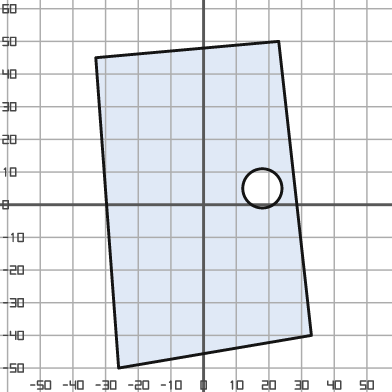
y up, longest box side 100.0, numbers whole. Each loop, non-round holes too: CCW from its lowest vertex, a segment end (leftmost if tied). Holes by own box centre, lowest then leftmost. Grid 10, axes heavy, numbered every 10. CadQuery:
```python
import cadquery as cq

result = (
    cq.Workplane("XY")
    .moveTo(-26.0, -50.0)
    .lineTo(33.0, -40.0)
    .lineTo(23.0, 50.0)
    .lineTo(-33.0, 45.0)
    .close()
    .moveTo(18.0, 5.0)
    .circle(6.0)
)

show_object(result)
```